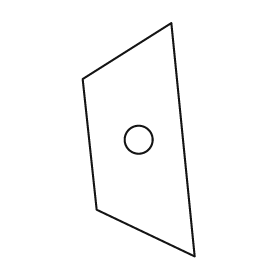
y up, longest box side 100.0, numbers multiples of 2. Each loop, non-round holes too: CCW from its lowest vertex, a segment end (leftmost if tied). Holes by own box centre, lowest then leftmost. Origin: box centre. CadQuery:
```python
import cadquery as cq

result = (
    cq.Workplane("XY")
    .moveTo(24.0, -50.0)
    .lineTo(14.0, 50.0)
    .lineTo(-24.0, 26.0)
    .lineTo(-18.0, -30.0)
    .close()
    .moveTo(0.0, 0.0)
    .circle(6.0)
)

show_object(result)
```